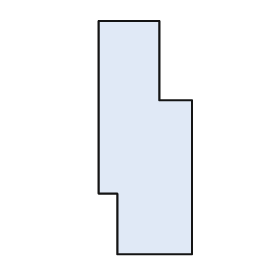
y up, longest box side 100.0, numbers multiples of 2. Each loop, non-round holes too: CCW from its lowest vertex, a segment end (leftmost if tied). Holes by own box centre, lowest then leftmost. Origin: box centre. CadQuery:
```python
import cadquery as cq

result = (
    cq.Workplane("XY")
    .moveTo(-12.0, -50.0)
    .lineTo(20.0, -50.0)
    .lineTo(20.0, 16.0)
    .lineTo(6.0, 16.0)
    .lineTo(6.0, 50.0)
    .lineTo(-20.0, 50.0)
    .lineTo(-20.0, -24.0)
    .lineTo(-12.0, -24.0)
    .close()
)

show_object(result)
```